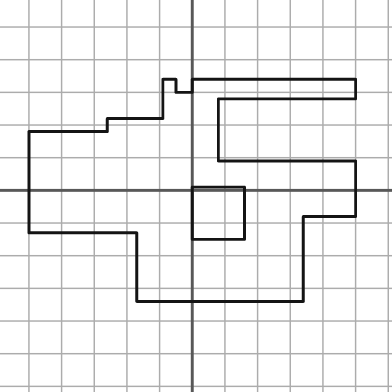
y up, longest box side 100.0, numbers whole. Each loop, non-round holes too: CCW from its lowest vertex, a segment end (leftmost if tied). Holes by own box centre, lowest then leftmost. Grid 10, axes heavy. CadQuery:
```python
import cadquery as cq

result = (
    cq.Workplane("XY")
    .moveTo(-17.0, -34.0)
    .lineTo(34.0, -34.0)
    .lineTo(34.0, -8.0)
    .lineTo(50.0, -8.0)
    .lineTo(50.0, 9.0)
    .lineTo(8.0, 9.0)
    .lineTo(8.0, 28.0)
    .lineTo(50.0, 28.0)
    .lineTo(50.0, 34.0)
    .lineTo(0.0, 34.0)
    .lineTo(0.0, 30.0)
    .lineTo(-5.0, 30.0)
    .lineTo(-5.0, 34.0)
    .lineTo(-9.0, 34.0)
    .lineTo(-9.0, 22.0)
    .lineTo(-26.0, 22.0)
    .lineTo(-26.0, 18.0)
    .lineTo(-50.0, 18.0)
    .lineTo(-50.0, -13.0)
    .lineTo(-17.0, -13.0)
    .close()
    .moveTo(0.0, -15.0)
    .lineTo(16.0, -15.0)
    .lineTo(16.0, 1.0)
    .lineTo(0.0, 1.0)
    .close()
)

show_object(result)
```